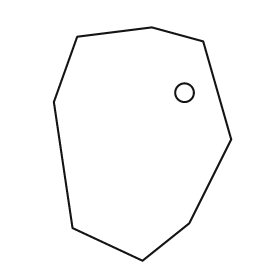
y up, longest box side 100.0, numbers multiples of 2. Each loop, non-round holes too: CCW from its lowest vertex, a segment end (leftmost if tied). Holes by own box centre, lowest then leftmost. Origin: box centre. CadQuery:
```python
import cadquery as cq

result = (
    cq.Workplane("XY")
    .moveTo(0.0, -50.0)
    .lineTo(20.0, -34.0)
    .lineTo(38.0, 2.0)
    .lineTo(26.0, 44.0)
    .lineTo(4.0, 50.0)
    .lineTo(-28.0, 46.0)
    .lineTo(-38.0, 18.0)
    .lineTo(-30.0, -36.0)
    .close()
    .moveTo(18.0, 22.0)
    .circle(4.0)
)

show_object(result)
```